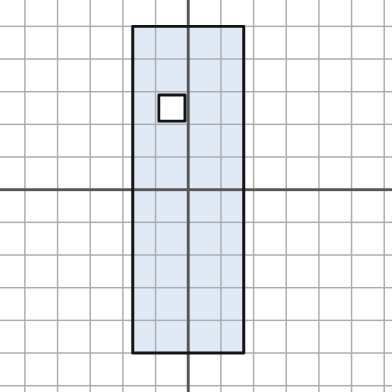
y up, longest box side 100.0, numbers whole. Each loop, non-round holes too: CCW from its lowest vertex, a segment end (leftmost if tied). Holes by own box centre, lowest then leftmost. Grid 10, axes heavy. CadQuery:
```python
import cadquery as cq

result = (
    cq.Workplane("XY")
    .moveTo(-17.0, -50.0)
    .lineTo(17.0, -50.0)
    .lineTo(17.0, 50.0)
    .lineTo(-17.0, 50.0)
    .close()
    .moveTo(-9.0, 21.0)
    .lineTo(-1.0, 21.0)
    .lineTo(-1.0, 29.0)
    .lineTo(-9.0, 29.0)
    .close()
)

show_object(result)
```